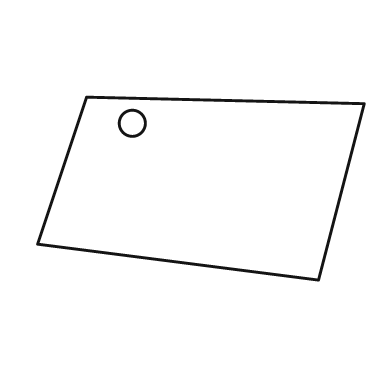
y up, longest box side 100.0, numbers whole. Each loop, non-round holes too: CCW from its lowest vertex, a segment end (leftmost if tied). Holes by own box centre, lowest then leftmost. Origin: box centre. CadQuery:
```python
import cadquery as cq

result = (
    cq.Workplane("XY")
    .moveTo(36.0, -28.0)
    .lineTo(50.0, 26.0)
    .lineTo(-35.0, 28.0)
    .lineTo(-50.0, -17.0)
    .close()
    .moveTo(-21.0, 20.0)
    .circle(4.0)
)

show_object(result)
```